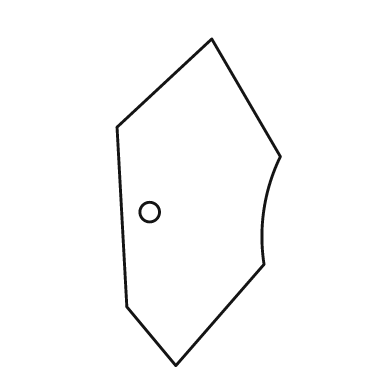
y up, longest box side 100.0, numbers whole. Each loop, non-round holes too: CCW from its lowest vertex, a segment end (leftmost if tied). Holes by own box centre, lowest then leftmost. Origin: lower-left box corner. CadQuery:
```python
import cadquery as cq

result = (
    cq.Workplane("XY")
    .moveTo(18.0, 0.0)
    .lineTo(45.0, 31.0)
    .threePointArc((45.0, 48.0), (50.0, 64.0))
    .lineTo(29.0, 100.0)
    .lineTo(0.0, 73.0)
    .lineTo(3.0, 18.0)
    .close()
    .moveTo(10.0, 47.0)
    .circle(3.0)
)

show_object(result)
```